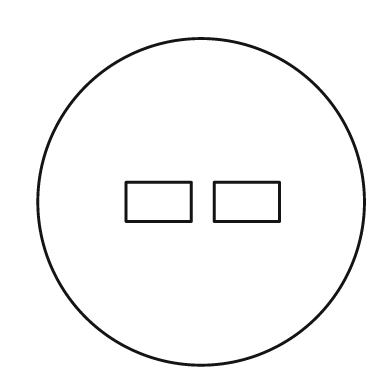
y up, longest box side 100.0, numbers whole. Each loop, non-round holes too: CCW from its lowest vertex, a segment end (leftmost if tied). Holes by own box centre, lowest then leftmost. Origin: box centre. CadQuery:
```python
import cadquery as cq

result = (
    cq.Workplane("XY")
    .moveTo(0.0, 0.0)
    .circle(50.0)
    .moveTo(-23.0, -6.0)
    .lineTo(-3.0, -6.0)
    .lineTo(-3.0, 6.0)
    .lineTo(-23.0, 6.0)
    .close()
    .moveTo(4.0, -6.0)
    .lineTo(24.0, -6.0)
    .lineTo(24.0, 6.0)
    .lineTo(4.0, 6.0)
    .close()
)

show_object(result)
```